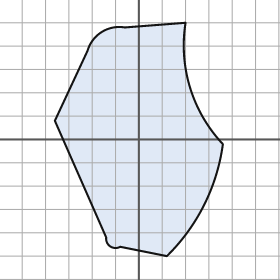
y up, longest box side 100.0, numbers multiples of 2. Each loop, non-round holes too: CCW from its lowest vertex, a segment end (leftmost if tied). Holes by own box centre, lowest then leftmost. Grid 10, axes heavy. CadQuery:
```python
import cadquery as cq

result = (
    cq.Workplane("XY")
    .moveTo(12.0, -50.0)
    .threePointArc((28.0, -28.0), (36.0, -2.0))
    .threePointArc((22.0, 22.0), (20.0, 50.0))
    .lineTo(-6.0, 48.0)
    .threePointArc((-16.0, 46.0), (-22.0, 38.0))
    .lineTo(-36.0, 8.0)
    .lineTo(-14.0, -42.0)
    .threePointArc((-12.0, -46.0), (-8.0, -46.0))
    .close()
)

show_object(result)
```